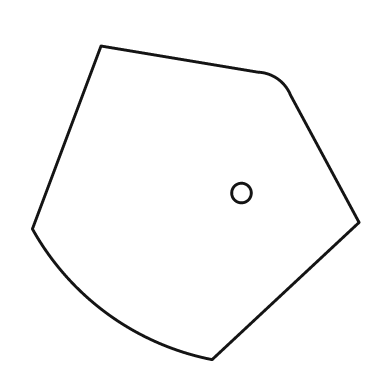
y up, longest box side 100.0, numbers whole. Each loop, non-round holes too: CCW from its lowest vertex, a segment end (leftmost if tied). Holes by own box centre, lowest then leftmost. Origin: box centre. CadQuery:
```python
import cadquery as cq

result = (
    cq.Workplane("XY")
    .moveTo(5.0, -48.0)
    .lineTo(50.0, -6.0)
    .lineTo(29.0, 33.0)
    .threePointArc((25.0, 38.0), (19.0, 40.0))
    .lineTo(-29.0, 48.0)
    .lineTo(-50.0, -8.0)
    .threePointArc((-27.0, -34.0), (5.0, -48.0))
    .close()
    .moveTo(14.0, 3.0)
    .circle(3.0)
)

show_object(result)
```